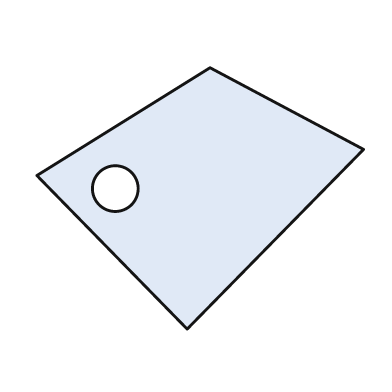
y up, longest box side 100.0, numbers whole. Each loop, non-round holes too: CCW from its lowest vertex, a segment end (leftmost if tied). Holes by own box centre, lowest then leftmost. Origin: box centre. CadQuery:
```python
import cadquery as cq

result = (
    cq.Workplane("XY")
    .moveTo(-4.0, -40.0)
    .lineTo(50.0, 15.0)
    .lineTo(3.0, 40.0)
    .lineTo(-50.0, 7.0)
    .close()
    .moveTo(-26.0, 3.0)
    .circle(7.0)
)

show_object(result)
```